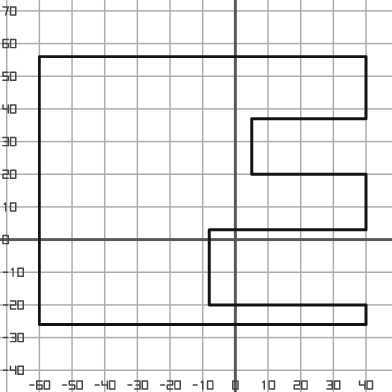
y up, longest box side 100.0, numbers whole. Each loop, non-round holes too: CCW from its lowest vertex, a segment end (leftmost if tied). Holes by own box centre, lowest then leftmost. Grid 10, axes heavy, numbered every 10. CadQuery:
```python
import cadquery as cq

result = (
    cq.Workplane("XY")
    .moveTo(-60.0, -26.0)
    .lineTo(40.0, -26.0)
    .lineTo(40.0, -20.0)
    .lineTo(-8.0, -20.0)
    .lineTo(-8.0, 3.0)
    .lineTo(40.0, 3.0)
    .lineTo(40.0, 20.0)
    .lineTo(5.0, 20.0)
    .lineTo(5.0, 37.0)
    .lineTo(40.0, 37.0)
    .lineTo(40.0, 56.0)
    .lineTo(-60.0, 56.0)
    .close()
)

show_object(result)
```